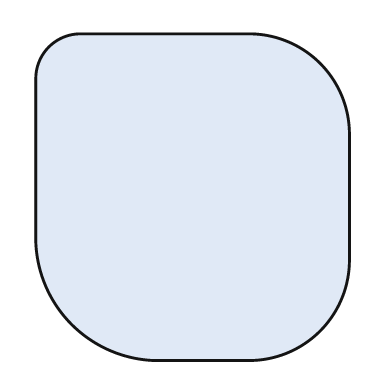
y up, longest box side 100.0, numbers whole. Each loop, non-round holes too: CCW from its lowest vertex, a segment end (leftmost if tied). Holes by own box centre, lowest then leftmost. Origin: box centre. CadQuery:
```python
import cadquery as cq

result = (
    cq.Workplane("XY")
    .moveTo(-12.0, -50.0)
    .lineTo(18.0, -50.0)
    .threePointArc((39.0, -41.0), (48.0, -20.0))
    .lineTo(48.0, 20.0)
    .threePointArc((39.0, 41.0), (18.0, 50.0))
    .lineTo(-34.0, 50.0)
    .threePointArc((-44.0, 46.0), (-48.0, 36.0))
    .lineTo(-48.0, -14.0)
    .threePointArc((-37.0, -39.0), (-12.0, -50.0))
    .close()
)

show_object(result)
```